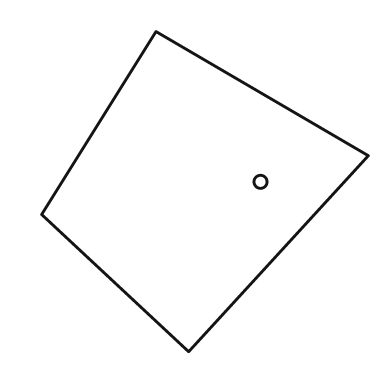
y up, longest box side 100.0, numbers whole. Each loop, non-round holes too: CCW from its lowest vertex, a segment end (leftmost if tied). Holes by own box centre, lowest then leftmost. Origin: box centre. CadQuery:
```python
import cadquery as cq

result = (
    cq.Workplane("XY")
    .moveTo(-5.0, -49.0)
    .lineTo(50.0, 11.0)
    .lineTo(-15.0, 49.0)
    .lineTo(-50.0, -7.0)
    .close()
    .moveTo(17.0, 3.0)
    .circle(2.0)
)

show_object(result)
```